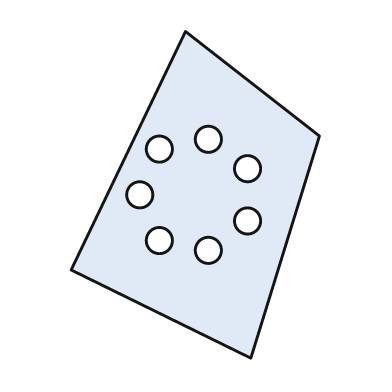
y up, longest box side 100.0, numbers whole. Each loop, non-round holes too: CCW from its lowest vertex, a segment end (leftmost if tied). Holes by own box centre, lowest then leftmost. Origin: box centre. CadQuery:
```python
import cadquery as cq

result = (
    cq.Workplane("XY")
    .moveTo(17.0, -50.0)
    .lineTo(38.0, 18.0)
    .lineTo(-3.0, 50.0)
    .lineTo(-38.0, -23.0)
    .close()
    .moveTo(4.0, -17.0)
    .circle(4.0)
    .moveTo(-11.0, -14.0)
    .circle(4.0)
    .moveTo(16.0, -8.0)
    .circle(4.0)
    .moveTo(-17.0, 0.0)
    .circle(4.0)
    .moveTo(16.0, 8.0)
    .circle(4.0)
    .moveTo(-11.0, 14.0)
    .circle(4.0)
    .moveTo(4.0, 17.0)
    .circle(4.0)
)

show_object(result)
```